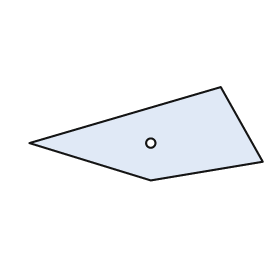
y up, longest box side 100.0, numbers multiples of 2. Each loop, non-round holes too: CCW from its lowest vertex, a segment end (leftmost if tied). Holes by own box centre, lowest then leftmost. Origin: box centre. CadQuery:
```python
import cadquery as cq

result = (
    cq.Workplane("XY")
    .moveTo(2.0, -20.0)
    .lineTo(50.0, -12.0)
    .lineTo(32.0, 20.0)
    .lineTo(-50.0, -4.0)
    .close()
    .moveTo(2.0, -4.0)
    .circle(2.0)
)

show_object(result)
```